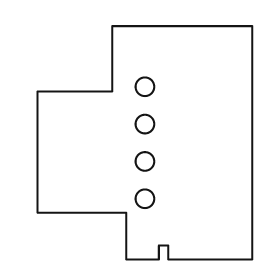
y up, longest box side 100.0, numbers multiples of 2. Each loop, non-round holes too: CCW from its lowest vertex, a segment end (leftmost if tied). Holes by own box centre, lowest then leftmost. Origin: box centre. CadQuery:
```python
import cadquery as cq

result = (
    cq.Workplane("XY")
    .moveTo(-8.0, -50.0)
    .lineTo(6.0, -50.0)
    .lineTo(6.0, -44.0)
    .lineTo(10.0, -44.0)
    .lineTo(10.0, -50.0)
    .lineTo(46.0, -50.0)
    .lineTo(46.0, 50.0)
    .lineTo(-14.0, 50.0)
    .lineTo(-14.0, 22.0)
    .lineTo(-46.0, 22.0)
    .lineTo(-46.0, -30.0)
    .lineTo(-8.0, -30.0)
    .close()
    .moveTo(0.0, -24.0)
    .circle(4.0)
    .moveTo(0.0, -8.0)
    .circle(4.0)
    .moveTo(0.0, 8.0)
    .circle(4.0)
    .moveTo(0.0, 24.0)
    .circle(4.0)
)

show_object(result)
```